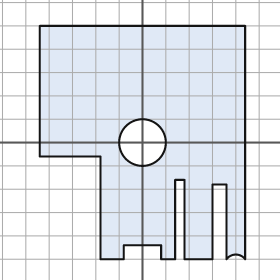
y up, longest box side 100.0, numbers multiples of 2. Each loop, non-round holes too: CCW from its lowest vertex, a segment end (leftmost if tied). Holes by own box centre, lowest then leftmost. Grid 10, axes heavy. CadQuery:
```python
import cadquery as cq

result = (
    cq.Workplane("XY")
    .moveTo(-18.0, -50.0)
    .lineTo(-8.0, -50.0)
    .lineTo(-8.0, -44.0)
    .lineTo(8.0, -44.0)
    .lineTo(8.0, -50.0)
    .lineTo(14.0, -50.0)
    .lineTo(14.0, -16.0)
    .lineTo(18.0, -16.0)
    .lineTo(18.0, -50.0)
    .lineTo(30.0, -50.0)
    .lineTo(30.0, -18.0)
    .lineTo(36.0, -18.0)
    .lineTo(36.0, -50.0)
    .threePointArc((40.0, -48.0), (44.0, -50.0))
    .lineTo(44.0, 50.0)
    .lineTo(-44.0, 50.0)
    .lineTo(-44.0, -6.0)
    .lineTo(-18.0, -6.0)
    .close()
    .moveTo(0.0, 0.0)
    .circle(10.0)
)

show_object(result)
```